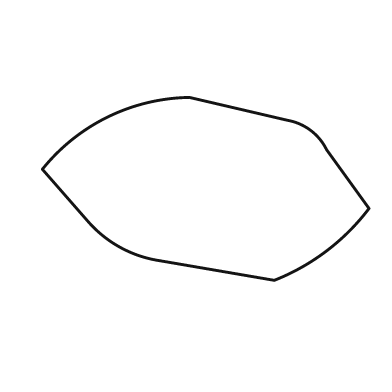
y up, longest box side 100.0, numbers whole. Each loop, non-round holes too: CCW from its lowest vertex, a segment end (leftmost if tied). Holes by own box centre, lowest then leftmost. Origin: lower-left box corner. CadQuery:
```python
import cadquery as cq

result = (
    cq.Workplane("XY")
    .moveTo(71.0, 0.0)
    .threePointArc((87.0, 9.0), (100.0, 22.0))
    .lineTo(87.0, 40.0)
    .threePointArc((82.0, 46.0), (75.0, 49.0))
    .lineTo(45.0, 56.0)
    .threePointArc((20.0, 50.0), (0.0, 34.0))
    .lineTo(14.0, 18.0)
    .threePointArc((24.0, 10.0), (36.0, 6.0))
    .close()
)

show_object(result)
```